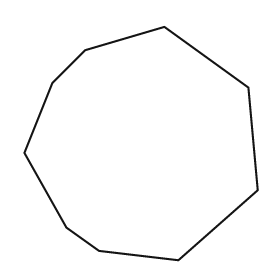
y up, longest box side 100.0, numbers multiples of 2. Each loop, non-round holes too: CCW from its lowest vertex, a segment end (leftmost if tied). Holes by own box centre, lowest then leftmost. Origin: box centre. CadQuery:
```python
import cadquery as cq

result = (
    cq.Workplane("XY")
    .moveTo(16.0, -50.0)
    .lineTo(50.0, -20.0)
    .lineTo(46.0, 24.0)
    .lineTo(10.0, 50.0)
    .lineTo(-24.0, 40.0)
    .lineTo(-38.0, 26.0)
    .lineTo(-50.0, -4.0)
    .lineTo(-32.0, -36.0)
    .lineTo(-18.0, -46.0)
    .close()
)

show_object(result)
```